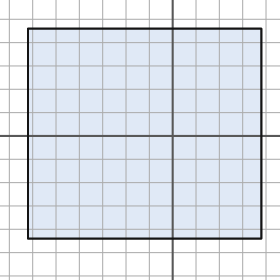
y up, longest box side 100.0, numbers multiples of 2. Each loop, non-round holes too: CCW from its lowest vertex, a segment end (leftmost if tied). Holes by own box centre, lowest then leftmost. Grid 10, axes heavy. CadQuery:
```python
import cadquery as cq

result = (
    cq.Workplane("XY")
    .moveTo(-62.0, -44.0)
    .lineTo(38.0, -44.0)
    .lineTo(38.0, 46.0)
    .lineTo(-62.0, 46.0)
    .close()
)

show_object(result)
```